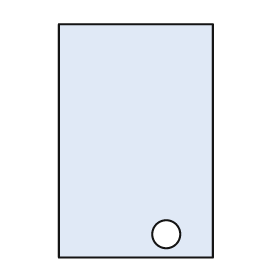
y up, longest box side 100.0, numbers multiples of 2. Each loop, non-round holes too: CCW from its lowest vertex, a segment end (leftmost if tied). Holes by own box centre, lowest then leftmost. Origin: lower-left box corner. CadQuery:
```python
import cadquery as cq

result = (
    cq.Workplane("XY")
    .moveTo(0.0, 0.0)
    .lineTo(66.0, 0.0)
    .lineTo(66.0, 100.0)
    .lineTo(0.0, 100.0)
    .close()
    .moveTo(46.0, 10.0)
    .circle(6.0)
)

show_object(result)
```